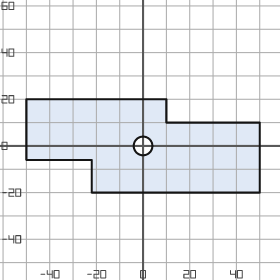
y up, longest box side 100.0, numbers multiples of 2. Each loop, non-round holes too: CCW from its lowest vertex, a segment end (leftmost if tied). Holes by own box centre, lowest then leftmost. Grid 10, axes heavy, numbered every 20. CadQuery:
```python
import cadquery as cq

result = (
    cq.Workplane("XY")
    .moveTo(-22.0, -20.0)
    .lineTo(50.0, -20.0)
    .lineTo(50.0, 10.0)
    .lineTo(10.0, 10.0)
    .lineTo(10.0, 20.0)
    .lineTo(-50.0, 20.0)
    .lineTo(-50.0, -6.0)
    .lineTo(-22.0, -6.0)
    .close()
    .moveTo(0.0, 0.0)
    .circle(4.0)
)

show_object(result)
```